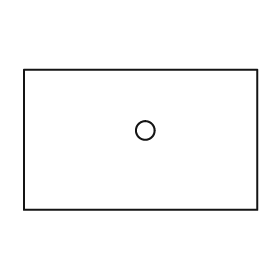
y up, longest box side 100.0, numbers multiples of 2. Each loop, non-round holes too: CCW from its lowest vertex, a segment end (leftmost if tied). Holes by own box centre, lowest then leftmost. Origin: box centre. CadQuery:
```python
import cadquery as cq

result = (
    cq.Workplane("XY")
    .moveTo(-50.0, -30.0)
    .lineTo(50.0, -30.0)
    .lineTo(50.0, 30.0)
    .lineTo(-50.0, 30.0)
    .close()
    .moveTo(2.0, 4.0)
    .circle(4.0)
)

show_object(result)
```